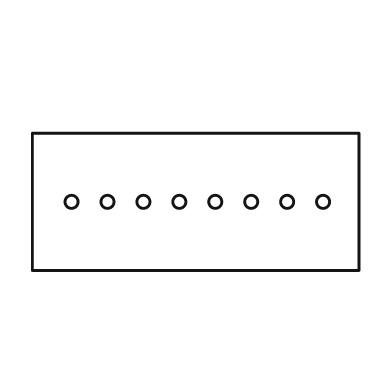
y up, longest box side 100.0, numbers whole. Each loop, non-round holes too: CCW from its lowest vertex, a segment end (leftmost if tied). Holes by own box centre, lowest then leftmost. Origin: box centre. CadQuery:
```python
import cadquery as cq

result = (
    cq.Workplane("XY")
    .moveTo(-50.0, -21.0)
    .lineTo(50.0, -21.0)
    .lineTo(50.0, 21.0)
    .lineTo(-50.0, 21.0)
    .close()
    .moveTo(-38.0, 0.0)
    .circle(2.0)
    .moveTo(-27.0, 0.0)
    .circle(2.0)
    .moveTo(-16.0, 0.0)
    .circle(2.0)
    .moveTo(-5.0, 0.0)
    .circle(2.0)
    .moveTo(6.0, 0.0)
    .circle(2.0)
    .moveTo(17.0, 0.0)
    .circle(2.0)
    .moveTo(28.0, 0.0)
    .circle(2.0)
    .moveTo(39.0, 0.0)
    .circle(2.0)
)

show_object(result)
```